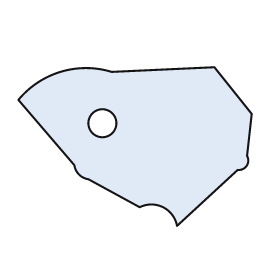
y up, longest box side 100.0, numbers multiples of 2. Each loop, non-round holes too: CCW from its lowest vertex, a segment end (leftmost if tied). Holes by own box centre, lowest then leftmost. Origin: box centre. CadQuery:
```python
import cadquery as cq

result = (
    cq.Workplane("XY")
    .moveTo(18.0, -34.0)
    .lineTo(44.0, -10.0)
    .threePointArc((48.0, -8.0), (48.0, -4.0))
    .lineTo(50.0, 14.0)
    .lineTo(34.0, 34.0)
    .lineTo(-10.0, 32.0)
    .threePointArc((-32.0, 32.0), (-50.0, 20.0))
    .lineTo(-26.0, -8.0)
    .threePointArc((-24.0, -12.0), (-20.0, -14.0))
    .lineTo(2.0, -26.0)
    .threePointArc((12.0, -26.0), (18.0, -34.0))
    .close()
    .moveTo(-14.0, 10.0)
    .circle(6.0)
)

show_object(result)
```